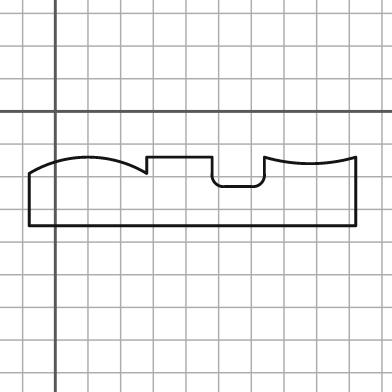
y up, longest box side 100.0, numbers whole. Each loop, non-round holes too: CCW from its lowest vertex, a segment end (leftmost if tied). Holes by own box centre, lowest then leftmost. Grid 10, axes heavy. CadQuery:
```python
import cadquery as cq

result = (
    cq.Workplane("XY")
    .moveTo(-8.0, -35.0)
    .lineTo(92.0, -35.0)
    .lineTo(92.0, -14.0)
    .threePointArc((78.0, -16.0), (64.0, -14.0))
    .lineTo(64.0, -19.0)
    .threePointArc((63.0, -22.0), (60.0, -23.0))
    .lineTo(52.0, -23.0)
    .threePointArc((49.0, -22.0), (48.0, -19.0))
    .lineTo(48.0, -14.0)
    .lineTo(28.0, -14.0)
    .lineTo(28.0, -19.0)
    .threePointArc((10.0, -14.0), (-8.0, -19.0))
    .close()
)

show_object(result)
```